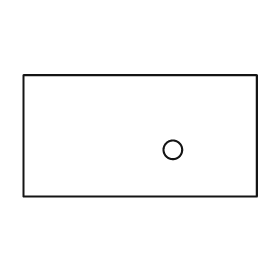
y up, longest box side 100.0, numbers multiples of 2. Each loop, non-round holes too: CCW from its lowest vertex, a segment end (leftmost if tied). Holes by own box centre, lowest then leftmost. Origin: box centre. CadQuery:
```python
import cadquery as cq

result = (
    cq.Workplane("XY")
    .moveTo(-50.0, -26.0)
    .lineTo(50.0, -26.0)
    .lineTo(50.0, 26.0)
    .lineTo(-50.0, 26.0)
    .close()
    .moveTo(14.0, -6.0)
    .circle(4.0)
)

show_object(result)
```